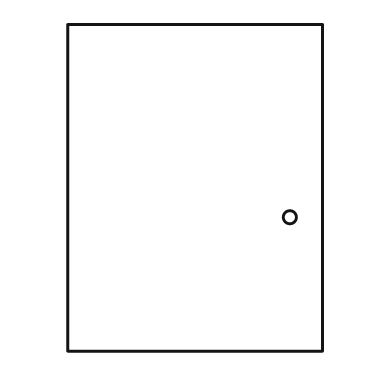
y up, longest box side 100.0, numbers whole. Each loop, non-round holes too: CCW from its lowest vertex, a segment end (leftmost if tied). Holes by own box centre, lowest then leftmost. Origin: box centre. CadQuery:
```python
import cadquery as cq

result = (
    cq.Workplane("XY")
    .moveTo(-39.0, -50.0)
    .lineTo(39.0, -50.0)
    .lineTo(39.0, 50.0)
    .lineTo(-39.0, 50.0)
    .close()
    .moveTo(29.0, -9.0)
    .circle(2.0)
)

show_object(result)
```